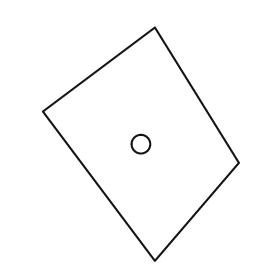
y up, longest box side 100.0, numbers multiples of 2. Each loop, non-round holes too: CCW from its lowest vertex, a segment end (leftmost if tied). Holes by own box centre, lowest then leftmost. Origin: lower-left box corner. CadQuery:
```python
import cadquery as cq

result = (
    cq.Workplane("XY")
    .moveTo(48.0, 0.0)
    .lineTo(84.0, 42.0)
    .lineTo(48.0, 100.0)
    .lineTo(0.0, 64.0)
    .close()
    .moveTo(42.0, 50.0)
    .circle(4.0)
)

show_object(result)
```